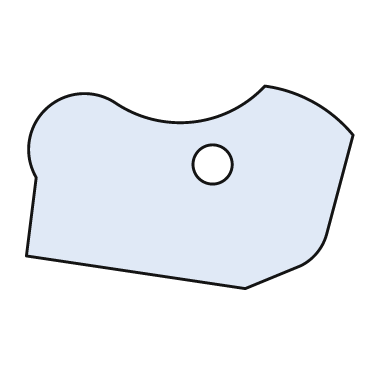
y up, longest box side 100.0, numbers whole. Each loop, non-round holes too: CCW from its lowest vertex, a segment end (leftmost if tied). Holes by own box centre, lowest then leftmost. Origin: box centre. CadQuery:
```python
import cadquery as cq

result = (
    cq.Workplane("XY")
    .moveTo(17.0, -31.0)
    .lineTo(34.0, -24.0)
    .threePointArc((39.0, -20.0), (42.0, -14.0))
    .lineTo(50.0, 16.0)
    .threePointArc((38.0, 26.0), (23.0, 31.0))
    .threePointArc((1.0, 20.0), (-23.0, 26.0))
    .threePointArc((-44.0, 24.0), (-47.0, 3.0))
    .lineTo(-50.0, -21.0)
    .close()
    .moveTo(7.0, 7.0)
    .circle(6.0)
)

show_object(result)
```